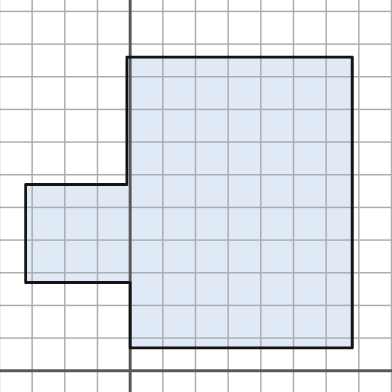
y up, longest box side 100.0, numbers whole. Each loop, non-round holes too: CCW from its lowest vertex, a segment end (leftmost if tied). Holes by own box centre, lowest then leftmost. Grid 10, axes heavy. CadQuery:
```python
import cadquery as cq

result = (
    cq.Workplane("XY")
    .moveTo(0.0, 7.0)
    .lineTo(68.0, 7.0)
    .lineTo(68.0, 96.0)
    .lineTo(-1.0, 96.0)
    .lineTo(-1.0, 57.0)
    .lineTo(-32.0, 57.0)
    .lineTo(-32.0, 27.0)
    .lineTo(0.0, 27.0)
    .close()
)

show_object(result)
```